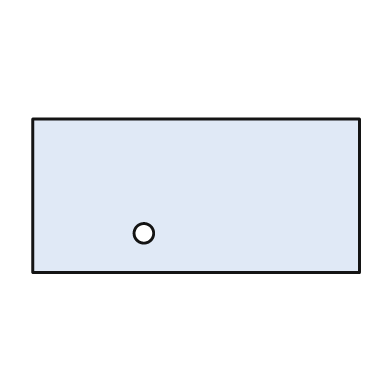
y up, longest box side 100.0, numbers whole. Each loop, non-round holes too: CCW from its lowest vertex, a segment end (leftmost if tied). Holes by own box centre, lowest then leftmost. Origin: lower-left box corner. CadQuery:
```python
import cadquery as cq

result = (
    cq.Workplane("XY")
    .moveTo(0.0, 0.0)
    .lineTo(100.0, 0.0)
    .lineTo(100.0, 47.0)
    .lineTo(0.0, 47.0)
    .close()
    .moveTo(34.0, 12.0)
    .circle(3.0)
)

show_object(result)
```